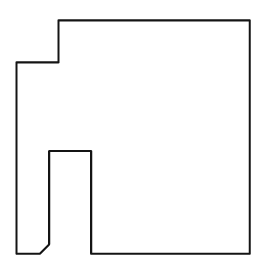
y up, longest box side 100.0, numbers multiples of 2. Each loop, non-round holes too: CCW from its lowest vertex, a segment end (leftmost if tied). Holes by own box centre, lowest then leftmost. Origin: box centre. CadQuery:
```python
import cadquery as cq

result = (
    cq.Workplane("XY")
    .moveTo(-50.0, -50.0)
    .lineTo(-40.0, -50.0)
    .lineTo(-36.0, -46.0)
    .lineTo(-36.0, -6.0)
    .lineTo(-18.0, -6.0)
    .lineTo(-18.0, -50.0)
    .lineTo(50.0, -50.0)
    .lineTo(50.0, 50.0)
    .lineTo(-32.0, 50.0)
    .lineTo(-32.0, 32.0)
    .lineTo(-50.0, 32.0)
    .close()
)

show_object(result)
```